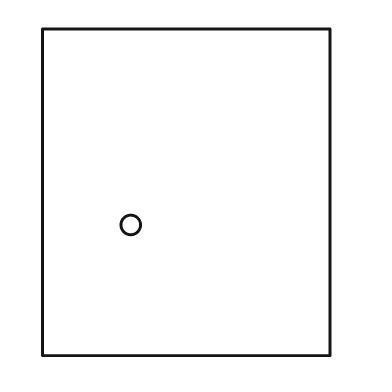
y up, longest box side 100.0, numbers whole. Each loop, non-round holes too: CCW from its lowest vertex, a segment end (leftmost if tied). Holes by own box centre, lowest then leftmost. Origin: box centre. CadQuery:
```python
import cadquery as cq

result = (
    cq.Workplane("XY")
    .moveTo(-44.0, -50.0)
    .lineTo(44.0, -50.0)
    .lineTo(44.0, 50.0)
    .lineTo(-44.0, 50.0)
    .close()
    .moveTo(-17.0, -10.0)
    .circle(3.0)
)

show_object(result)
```